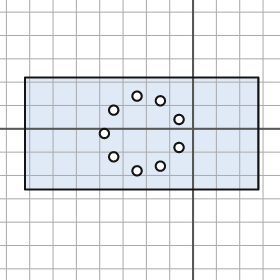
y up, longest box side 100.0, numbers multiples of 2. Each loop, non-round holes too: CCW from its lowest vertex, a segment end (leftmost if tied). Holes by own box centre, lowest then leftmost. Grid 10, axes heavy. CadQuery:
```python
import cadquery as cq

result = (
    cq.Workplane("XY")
    .moveTo(-72.0, -26.0)
    .lineTo(28.0, -26.0)
    .lineTo(28.0, 22.0)
    .lineTo(-72.0, 22.0)
    .close()
    .moveTo(-24.0, -18.0)
    .circle(2.0)
    .moveTo(-14.0, -16.0)
    .circle(2.0)
    .moveTo(-34.0, -12.0)
    .circle(2.0)
    .moveTo(-6.0, -8.0)
    .circle(2.0)
    .moveTo(-38.0, -2.0)
    .circle(2.0)
    .moveTo(-6.0, 4.0)
    .circle(2.0)
    .moveTo(-34.0, 8.0)
    .circle(2.0)
    .moveTo(-14.0, 12.0)
    .circle(2.0)
    .moveTo(-24.0, 14.0)
    .circle(2.0)
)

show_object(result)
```